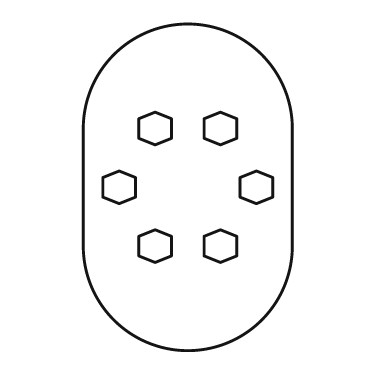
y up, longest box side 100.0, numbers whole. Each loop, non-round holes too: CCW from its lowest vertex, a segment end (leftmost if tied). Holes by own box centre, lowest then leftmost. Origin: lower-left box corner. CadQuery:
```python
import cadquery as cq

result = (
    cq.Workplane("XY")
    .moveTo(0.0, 32.0)
    .threePointArc((32.0, 0.0), (64.0, 32.0))
    .lineTo(64.0, 68.0)
    .threePointArc((32.0, 100.0), (0.0, 68.0))
    .close()
    .moveTo(22.0, 27.0)
    .lineTo(27.0, 29.0)
    .lineTo(27.0, 35.0)
    .lineTo(22.0, 37.0)
    .lineTo(17.0, 35.0)
    .lineTo(17.0, 29.0)
    .close()
    .moveTo(42.0, 27.0)
    .lineTo(47.0, 29.0)
    .lineTo(47.0, 35.0)
    .lineTo(42.0, 37.0)
    .lineTo(37.0, 35.0)
    .lineTo(37.0, 29.0)
    .close()
    .moveTo(11.0, 45.0)
    .lineTo(16.0, 47.0)
    .lineTo(16.0, 53.0)
    .lineTo(11.0, 55.0)
    .lineTo(6.0, 53.0)
    .lineTo(6.0, 47.0)
    .close()
    .moveTo(53.0, 45.0)
    .lineTo(58.0, 47.0)
    .lineTo(58.0, 53.0)
    .lineTo(53.0, 55.0)
    .lineTo(48.0, 53.0)
    .lineTo(48.0, 47.0)
    .close()
    .moveTo(22.0, 63.0)
    .lineTo(27.0, 65.0)
    .lineTo(27.0, 71.0)
    .lineTo(22.0, 73.0)
    .lineTo(17.0, 71.0)
    .lineTo(17.0, 65.0)
    .close()
    .moveTo(42.0, 63.0)
    .lineTo(47.0, 65.0)
    .lineTo(47.0, 71.0)
    .lineTo(42.0, 73.0)
    .lineTo(37.0, 71.0)
    .lineTo(37.0, 65.0)
    .close()
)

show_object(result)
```